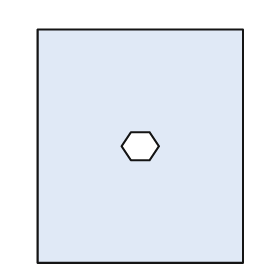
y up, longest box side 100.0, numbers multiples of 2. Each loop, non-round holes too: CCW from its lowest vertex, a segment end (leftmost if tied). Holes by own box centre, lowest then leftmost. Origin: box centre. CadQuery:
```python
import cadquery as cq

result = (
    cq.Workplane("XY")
    .moveTo(-44.0, -50.0)
    .lineTo(44.0, -50.0)
    .lineTo(44.0, 50.0)
    .lineTo(-44.0, 50.0)
    .close()
    .moveTo(-4.0, -6.0)
    .lineTo(4.0, -6.0)
    .lineTo(8.0, 0.0)
    .lineTo(4.0, 6.0)
    .lineTo(-4.0, 6.0)
    .lineTo(-8.0, 0.0)
    .close()
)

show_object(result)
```